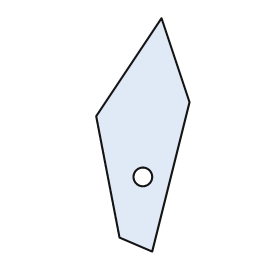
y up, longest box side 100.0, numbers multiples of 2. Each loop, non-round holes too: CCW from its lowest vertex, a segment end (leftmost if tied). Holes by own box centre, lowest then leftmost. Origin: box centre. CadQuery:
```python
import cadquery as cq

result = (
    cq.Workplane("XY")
    .moveTo(4.0, -50.0)
    .lineTo(20.0, 14.0)
    .lineTo(8.0, 50.0)
    .lineTo(-20.0, 8.0)
    .lineTo(-10.0, -44.0)
    .close()
    .moveTo(0.0, -18.0)
    .circle(4.0)
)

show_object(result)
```